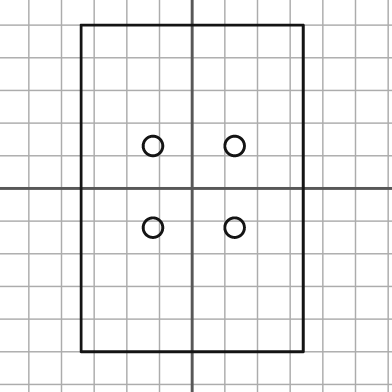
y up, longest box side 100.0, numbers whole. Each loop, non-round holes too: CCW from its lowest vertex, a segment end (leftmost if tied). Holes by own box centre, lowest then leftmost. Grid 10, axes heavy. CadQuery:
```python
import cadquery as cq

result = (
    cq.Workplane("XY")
    .moveTo(-34.0, -50.0)
    .lineTo(34.0, -50.0)
    .lineTo(34.0, 50.0)
    .lineTo(-34.0, 50.0)
    .close()
    .moveTo(-12.0, -12.0)
    .circle(3.0)
    .moveTo(13.0, -12.0)
    .circle(3.0)
    .moveTo(-12.0, 13.0)
    .circle(3.0)
    .moveTo(13.0, 13.0)
    .circle(3.0)
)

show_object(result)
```